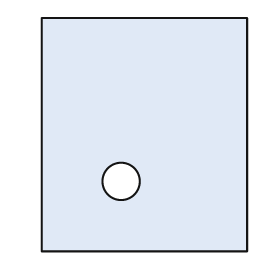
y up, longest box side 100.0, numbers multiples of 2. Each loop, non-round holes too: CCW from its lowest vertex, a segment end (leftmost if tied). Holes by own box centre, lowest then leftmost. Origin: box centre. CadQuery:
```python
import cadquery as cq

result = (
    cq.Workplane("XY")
    .moveTo(-44.0, -50.0)
    .lineTo(44.0, -50.0)
    .lineTo(44.0, 50.0)
    .lineTo(-44.0, 50.0)
    .close()
    .moveTo(-10.0, -20.0)
    .circle(8.0)
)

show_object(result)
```